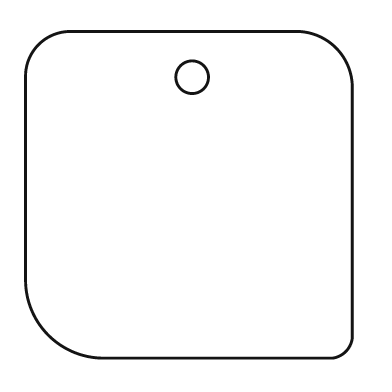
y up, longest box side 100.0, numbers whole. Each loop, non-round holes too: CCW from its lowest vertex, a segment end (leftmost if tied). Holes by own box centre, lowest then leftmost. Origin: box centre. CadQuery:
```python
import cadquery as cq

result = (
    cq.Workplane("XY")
    .moveTo(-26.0, -50.0)
    .lineTo(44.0, -50.0)
    .threePointArc((48.0, -48.0), (50.0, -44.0))
    .lineTo(50.0, 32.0)
    .threePointArc((45.0, 45.0), (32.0, 50.0))
    .lineTo(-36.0, 50.0)
    .threePointArc((-46.0, 46.0), (-50.0, 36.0))
    .lineTo(-50.0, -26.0)
    .threePointArc((-43.0, -43.0), (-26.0, -50.0))
    .close()
    .moveTo(1.0, 36.0)
    .circle(5.0)
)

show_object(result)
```